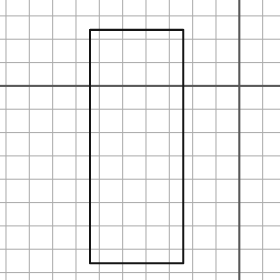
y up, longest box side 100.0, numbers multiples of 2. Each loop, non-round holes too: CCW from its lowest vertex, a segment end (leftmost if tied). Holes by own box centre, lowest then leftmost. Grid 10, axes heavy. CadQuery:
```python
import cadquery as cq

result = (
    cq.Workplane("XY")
    .moveTo(-64.0, -76.0)
    .lineTo(-24.0, -76.0)
    .lineTo(-24.0, 24.0)
    .lineTo(-64.0, 24.0)
    .close()
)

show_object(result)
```